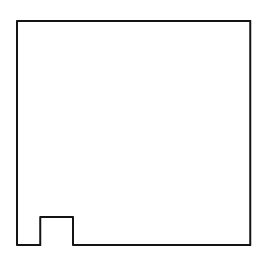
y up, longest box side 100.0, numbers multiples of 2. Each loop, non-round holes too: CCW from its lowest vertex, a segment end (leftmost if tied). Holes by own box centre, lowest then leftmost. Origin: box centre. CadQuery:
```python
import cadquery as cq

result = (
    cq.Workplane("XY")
    .moveTo(-50.0, -48.0)
    .lineTo(-40.0, -48.0)
    .lineTo(-40.0, -36.0)
    .lineTo(-26.0, -36.0)
    .lineTo(-26.0, -48.0)
    .lineTo(50.0, -48.0)
    .lineTo(50.0, 48.0)
    .lineTo(-50.0, 48.0)
    .close()
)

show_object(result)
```